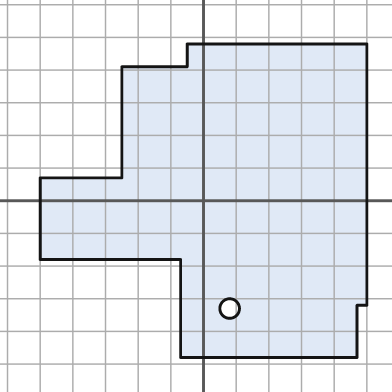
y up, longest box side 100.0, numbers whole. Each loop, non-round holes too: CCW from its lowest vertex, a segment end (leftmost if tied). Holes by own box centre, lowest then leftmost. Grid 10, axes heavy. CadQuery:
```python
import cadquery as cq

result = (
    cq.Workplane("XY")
    .moveTo(-7.0, -48.0)
    .lineTo(47.0, -48.0)
    .lineTo(47.0, -32.0)
    .lineTo(50.0, -32.0)
    .lineTo(50.0, 48.0)
    .lineTo(-5.0, 48.0)
    .lineTo(-5.0, 41.0)
    .lineTo(-25.0, 41.0)
    .lineTo(-25.0, 7.0)
    .lineTo(-50.0, 7.0)
    .lineTo(-50.0, -18.0)
    .lineTo(-7.0, -18.0)
    .close()
    .moveTo(8.0, -33.0)
    .circle(3.0)
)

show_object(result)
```